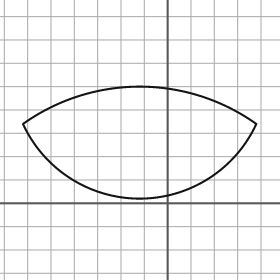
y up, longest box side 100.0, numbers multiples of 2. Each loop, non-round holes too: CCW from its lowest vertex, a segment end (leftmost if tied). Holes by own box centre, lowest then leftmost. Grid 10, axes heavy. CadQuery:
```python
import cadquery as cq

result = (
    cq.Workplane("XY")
    .moveTo(-62.0, 34.0)
    .threePointArc((-12.0, 2.0), (38.0, 34.0))
    .threePointArc((-12.0, 50.0), (-62.0, 34.0))
    .close()
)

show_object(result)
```